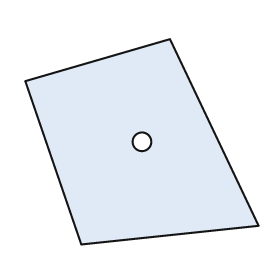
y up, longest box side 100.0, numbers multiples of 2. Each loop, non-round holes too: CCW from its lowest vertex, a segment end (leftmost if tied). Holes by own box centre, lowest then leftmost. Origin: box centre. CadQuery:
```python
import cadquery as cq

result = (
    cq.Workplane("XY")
    .moveTo(-26.0, -44.0)
    .lineTo(50.0, -36.0)
    .lineTo(12.0, 44.0)
    .lineTo(-50.0, 26.0)
    .close()
    .moveTo(0.0, 0.0)
    .circle(4.0)
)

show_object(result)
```